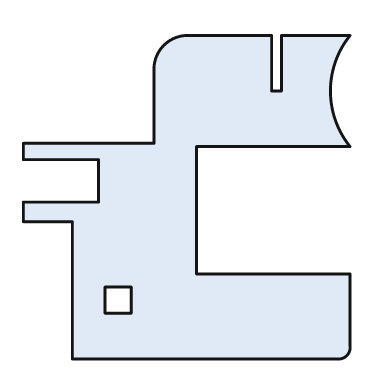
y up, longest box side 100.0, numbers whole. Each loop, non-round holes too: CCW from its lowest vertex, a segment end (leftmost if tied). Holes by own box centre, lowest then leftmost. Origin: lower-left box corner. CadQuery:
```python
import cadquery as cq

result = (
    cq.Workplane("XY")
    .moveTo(15.0, 0.0)
    .lineTo(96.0, 0.0)
    .threePointArc((99.0, 1.0), (100.0, 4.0))
    .lineTo(100.0, 26.0)
    .lineTo(53.0, 26.0)
    .lineTo(53.0, 65.0)
    .lineTo(100.0, 65.0)
    .threePointArc((94.0, 82.0), (100.0, 99.0))
    .lineTo(79.0, 99.0)
    .lineTo(79.0, 82.0)
    .lineTo(76.0, 82.0)
    .lineTo(76.0, 99.0)
    .lineTo(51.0, 99.0)
    .threePointArc((43.0, 96.0), (40.0, 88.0))
    .lineTo(40.0, 66.0)
    .lineTo(0.0, 66.0)
    .lineTo(0.0, 61.0)
    .lineTo(23.0, 61.0)
    .lineTo(23.0, 48.0)
    .lineTo(0.0, 48.0)
    .lineTo(0.0, 42.0)
    .lineTo(15.0, 42.0)
    .close()
    .moveTo(25.0, 14.0)
    .lineTo(33.0, 14.0)
    .lineTo(33.0, 22.0)
    .lineTo(25.0, 22.0)
    .close()
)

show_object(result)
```